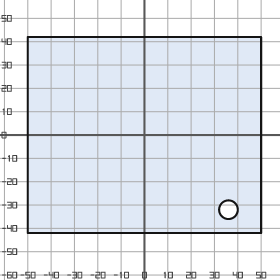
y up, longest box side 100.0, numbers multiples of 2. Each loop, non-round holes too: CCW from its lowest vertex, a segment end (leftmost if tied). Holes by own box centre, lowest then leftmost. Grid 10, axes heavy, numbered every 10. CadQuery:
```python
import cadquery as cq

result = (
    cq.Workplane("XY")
    .moveTo(-50.0, -42.0)
    .lineTo(50.0, -42.0)
    .lineTo(50.0, 42.0)
    .lineTo(-50.0, 42.0)
    .close()
    .moveTo(36.0, -32.0)
    .circle(4.0)
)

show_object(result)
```